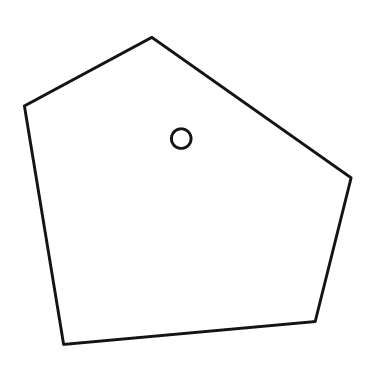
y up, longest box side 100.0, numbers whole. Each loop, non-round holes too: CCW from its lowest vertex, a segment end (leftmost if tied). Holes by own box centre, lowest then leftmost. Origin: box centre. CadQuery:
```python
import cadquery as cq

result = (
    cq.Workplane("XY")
    .moveTo(-38.0, -47.0)
    .lineTo(39.0, -40.0)
    .lineTo(50.0, 4.0)
    .lineTo(-11.0, 47.0)
    .lineTo(-50.0, 26.0)
    .close()
    .moveTo(-2.0, 16.0)
    .circle(3.0)
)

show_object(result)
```